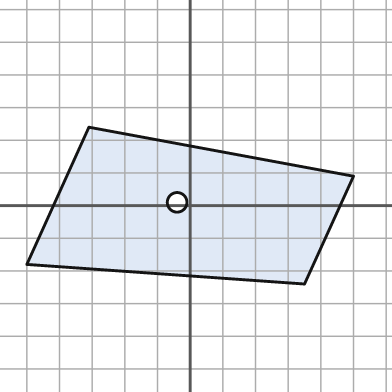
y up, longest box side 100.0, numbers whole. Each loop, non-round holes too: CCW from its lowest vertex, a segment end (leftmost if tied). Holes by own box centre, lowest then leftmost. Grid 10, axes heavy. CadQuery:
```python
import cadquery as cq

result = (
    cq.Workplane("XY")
    .moveTo(35.0, -24.0)
    .lineTo(50.0, 9.0)
    .lineTo(-31.0, 24.0)
    .lineTo(-50.0, -18.0)
    .close()
    .moveTo(-4.0, 1.0)
    .circle(3.0)
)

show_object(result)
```